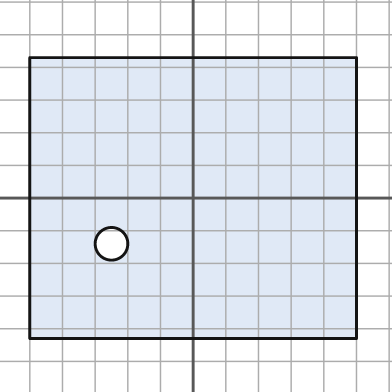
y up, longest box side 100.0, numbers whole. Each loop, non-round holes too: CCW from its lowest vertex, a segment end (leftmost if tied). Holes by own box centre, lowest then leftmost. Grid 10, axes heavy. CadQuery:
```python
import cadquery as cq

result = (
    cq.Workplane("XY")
    .moveTo(-50.0, -43.0)
    .lineTo(50.0, -43.0)
    .lineTo(50.0, 43.0)
    .lineTo(-50.0, 43.0)
    .close()
    .moveTo(-25.0, -14.0)
    .circle(5.0)
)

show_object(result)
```